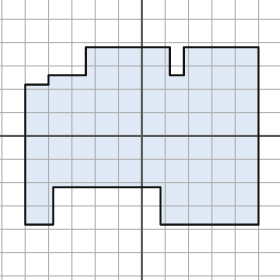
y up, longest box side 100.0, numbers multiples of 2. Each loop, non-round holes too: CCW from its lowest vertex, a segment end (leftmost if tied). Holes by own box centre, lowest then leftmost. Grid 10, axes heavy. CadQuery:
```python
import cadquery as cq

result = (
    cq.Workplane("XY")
    .moveTo(-50.0, -38.0)
    .lineTo(-38.0, -38.0)
    .lineTo(-38.0, -22.0)
    .lineTo(8.0, -22.0)
    .lineTo(8.0, -38.0)
    .lineTo(50.0, -38.0)
    .lineTo(50.0, 38.0)
    .lineTo(18.0, 38.0)
    .lineTo(18.0, 26.0)
    .lineTo(12.0, 26.0)
    .lineTo(12.0, 38.0)
    .lineTo(-24.0, 38.0)
    .lineTo(-24.0, 26.0)
    .lineTo(-40.0, 26.0)
    .lineTo(-40.0, 22.0)
    .lineTo(-50.0, 22.0)
    .close()
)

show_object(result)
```